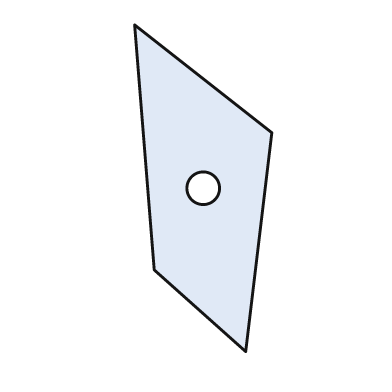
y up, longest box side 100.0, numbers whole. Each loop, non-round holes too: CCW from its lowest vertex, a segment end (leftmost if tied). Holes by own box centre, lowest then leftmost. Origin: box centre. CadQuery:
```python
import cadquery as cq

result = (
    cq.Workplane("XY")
    .moveTo(13.0, -50.0)
    .lineTo(21.0, 17.0)
    .lineTo(-21.0, 50.0)
    .lineTo(-15.0, -25.0)
    .close()
    .moveTo(0.0, 0.0)
    .circle(5.0)
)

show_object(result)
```